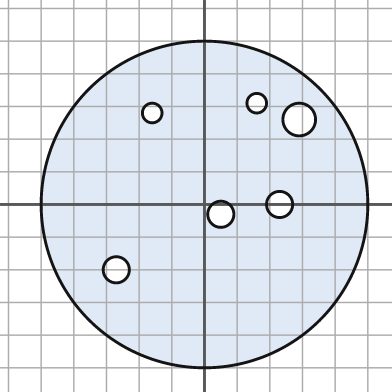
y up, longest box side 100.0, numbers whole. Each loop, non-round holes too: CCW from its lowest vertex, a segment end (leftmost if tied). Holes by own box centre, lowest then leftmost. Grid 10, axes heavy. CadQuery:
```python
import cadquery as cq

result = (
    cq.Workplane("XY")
    .moveTo(0.0, 0.0)
    .circle(50.0)
    .moveTo(-27.0, -20.0)
    .circle(4.0)
    .moveTo(5.0, -3.0)
    .circle(4.0)
    .moveTo(23.0, 0.0)
    .circle(4.0)
    .moveTo(29.0, 26.0)
    .circle(5.0)
    .moveTo(-16.0, 28.0)
    .circle(3.0)
    .moveTo(16.0, 31.0)
    .circle(3.0)
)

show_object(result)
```